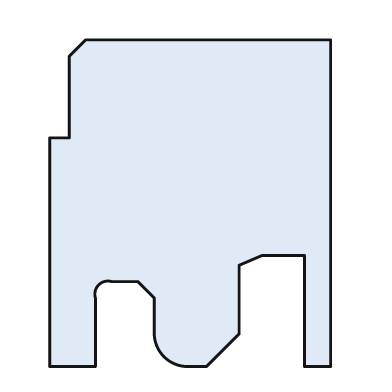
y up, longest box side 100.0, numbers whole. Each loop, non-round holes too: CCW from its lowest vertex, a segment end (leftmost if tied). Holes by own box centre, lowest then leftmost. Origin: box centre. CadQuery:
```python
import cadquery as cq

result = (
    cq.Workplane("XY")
    .moveTo(-43.0, -50.0)
    .lineTo(-29.0, -50.0)
    .lineTo(-29.0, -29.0)
    .threePointArc((-28.0, -25.0), (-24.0, -24.0))
    .lineTo(-16.0, -24.0)
    .lineTo(-11.0, -29.0)
    .lineTo(-11.0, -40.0)
    .threePointArc((-8.0, -47.0), (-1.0, -50.0))
    .lineTo(5.0, -50.0)
    .lineTo(15.0, -40.0)
    .lineTo(15.0, -19.0)
    .lineTo(22.0, -16.0)
    .lineTo(35.0, -16.0)
    .lineTo(35.0, -50.0)
    .lineTo(43.0, -50.0)
    .lineTo(43.0, 50.0)
    .lineTo(-32.0, 50.0)
    .lineTo(-37.0, 45.0)
    .lineTo(-37.0, 20.0)
    .lineTo(-43.0, 20.0)
    .close()
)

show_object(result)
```